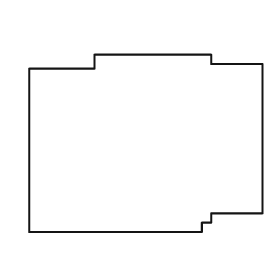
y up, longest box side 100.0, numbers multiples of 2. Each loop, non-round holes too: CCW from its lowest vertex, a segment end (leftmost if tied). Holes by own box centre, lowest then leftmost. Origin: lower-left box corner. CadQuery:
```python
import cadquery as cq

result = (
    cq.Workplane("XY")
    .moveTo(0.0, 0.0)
    .lineTo(74.0, 0.0)
    .lineTo(74.0, 4.0)
    .lineTo(78.0, 4.0)
    .lineTo(78.0, 8.0)
    .lineTo(100.0, 8.0)
    .lineTo(100.0, 72.0)
    .lineTo(78.0, 72.0)
    .lineTo(78.0, 76.0)
    .lineTo(28.0, 76.0)
    .lineTo(28.0, 70.0)
    .lineTo(0.0, 70.0)
    .close()
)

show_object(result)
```